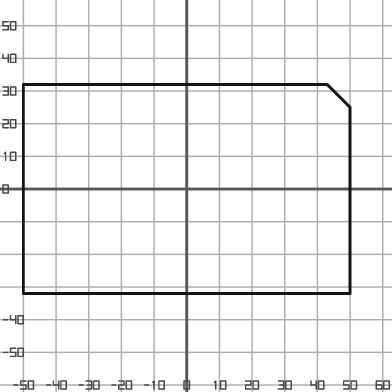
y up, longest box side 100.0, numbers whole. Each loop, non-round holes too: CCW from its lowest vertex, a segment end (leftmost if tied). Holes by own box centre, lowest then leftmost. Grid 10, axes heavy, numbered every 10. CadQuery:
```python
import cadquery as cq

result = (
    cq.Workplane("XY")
    .moveTo(-50.0, -32.0)
    .lineTo(50.0, -32.0)
    .lineTo(50.0, 25.0)
    .lineTo(43.0, 32.0)
    .lineTo(-50.0, 32.0)
    .close()
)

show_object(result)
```